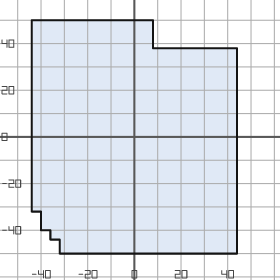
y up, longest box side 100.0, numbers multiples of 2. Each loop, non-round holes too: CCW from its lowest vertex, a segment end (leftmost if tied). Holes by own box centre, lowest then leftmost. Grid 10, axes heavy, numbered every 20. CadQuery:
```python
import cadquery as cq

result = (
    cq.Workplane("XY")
    .moveTo(-32.0, -50.0)
    .lineTo(44.0, -50.0)
    .lineTo(44.0, 38.0)
    .lineTo(8.0, 38.0)
    .lineTo(8.0, 50.0)
    .lineTo(-44.0, 50.0)
    .lineTo(-44.0, -32.0)
    .lineTo(-40.0, -32.0)
    .lineTo(-40.0, -40.0)
    .lineTo(-36.0, -40.0)
    .lineTo(-36.0, -44.0)
    .lineTo(-32.0, -44.0)
    .close()
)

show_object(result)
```